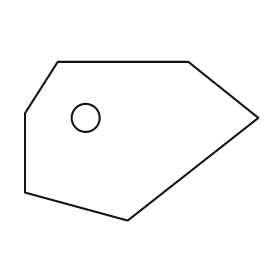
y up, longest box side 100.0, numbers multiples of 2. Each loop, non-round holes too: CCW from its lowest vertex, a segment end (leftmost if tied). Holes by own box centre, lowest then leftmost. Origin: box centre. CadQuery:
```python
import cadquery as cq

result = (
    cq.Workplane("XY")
    .moveTo(-6.0, -34.0)
    .lineTo(50.0, 10.0)
    .lineTo(20.0, 34.0)
    .lineTo(-36.0, 34.0)
    .lineTo(-50.0, 12.0)
    .lineTo(-50.0, -22.0)
    .close()
    .moveTo(-24.0, 10.0)
    .circle(6.0)
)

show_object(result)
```